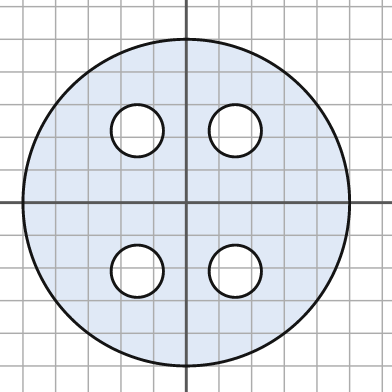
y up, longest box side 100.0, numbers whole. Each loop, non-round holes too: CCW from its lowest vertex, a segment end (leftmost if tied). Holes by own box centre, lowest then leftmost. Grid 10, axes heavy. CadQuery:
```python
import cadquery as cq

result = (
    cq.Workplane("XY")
    .moveTo(0.0, 0.0)
    .circle(50.0)
    .moveTo(-15.0, -21.0)
    .circle(8.0)
    .moveTo(15.0, -21.0)
    .circle(8.0)
    .moveTo(-15.0, 22.0)
    .circle(8.0)
    .moveTo(15.0, 22.0)
    .circle(8.0)
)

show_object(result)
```